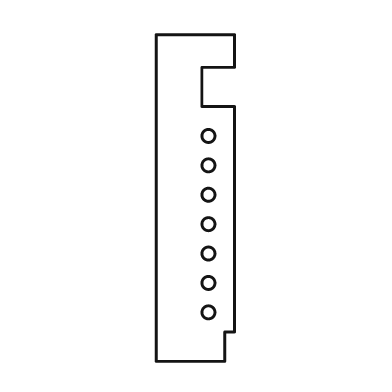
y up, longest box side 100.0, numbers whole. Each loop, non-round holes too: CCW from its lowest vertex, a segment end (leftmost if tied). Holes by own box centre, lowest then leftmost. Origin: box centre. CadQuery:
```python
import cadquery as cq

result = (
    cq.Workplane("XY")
    .moveTo(-12.0, -50.0)
    .lineTo(9.0, -50.0)
    .lineTo(9.0, -41.0)
    .lineTo(12.0, -41.0)
    .lineTo(12.0, 28.0)
    .lineTo(2.0, 28.0)
    .lineTo(2.0, 40.0)
    .lineTo(12.0, 40.0)
    .lineTo(12.0, 50.0)
    .lineTo(-12.0, 50.0)
    .close()
    .moveTo(4.0, -35.0)
    .circle(2.0)
    .moveTo(4.0, -26.0)
    .circle(2.0)
    .moveTo(4.0, -17.0)
    .circle(2.0)
    .moveTo(4.0, -8.0)
    .circle(2.0)
    .moveTo(4.0, 1.0)
    .circle(2.0)
    .moveTo(4.0, 10.0)
    .circle(2.0)
    .moveTo(4.0, 19.0)
    .circle(2.0)
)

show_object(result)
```